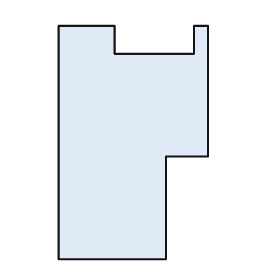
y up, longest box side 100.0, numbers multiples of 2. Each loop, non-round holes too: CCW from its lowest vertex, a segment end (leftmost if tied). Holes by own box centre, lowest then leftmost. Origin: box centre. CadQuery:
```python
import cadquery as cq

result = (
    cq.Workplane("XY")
    .moveTo(-32.0, -50.0)
    .lineTo(14.0, -50.0)
    .lineTo(14.0, -6.0)
    .lineTo(32.0, -6.0)
    .lineTo(32.0, 50.0)
    .lineTo(26.0, 50.0)
    .lineTo(26.0, 38.0)
    .lineTo(-8.0, 38.0)
    .lineTo(-8.0, 50.0)
    .lineTo(-32.0, 50.0)
    .close()
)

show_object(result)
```